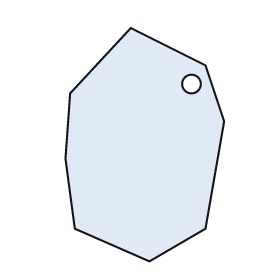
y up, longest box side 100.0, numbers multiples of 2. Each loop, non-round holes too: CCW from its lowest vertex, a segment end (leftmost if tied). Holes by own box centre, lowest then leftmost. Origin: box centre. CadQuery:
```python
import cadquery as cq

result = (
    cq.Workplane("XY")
    .moveTo(2.0, -50.0)
    .lineTo(26.0, -36.0)
    .lineTo(34.0, 10.0)
    .lineTo(26.0, 34.0)
    .lineTo(-6.0, 50.0)
    .lineTo(-32.0, 22.0)
    .lineTo(-34.0, -6.0)
    .lineTo(-30.0, -36.0)
    .close()
    .moveTo(20.0, 26.0)
    .circle(4.0)
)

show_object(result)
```